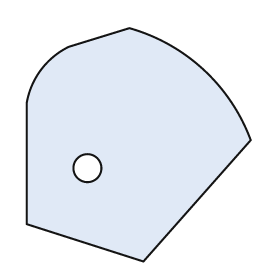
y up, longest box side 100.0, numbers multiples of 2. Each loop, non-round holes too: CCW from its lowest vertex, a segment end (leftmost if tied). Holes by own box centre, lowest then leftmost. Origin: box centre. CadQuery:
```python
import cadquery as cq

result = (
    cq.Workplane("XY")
    .moveTo(2.0, -50.0)
    .lineTo(48.0, 2.0)
    .threePointArc((28.0, 32.0), (-4.0, 50.0))
    .lineTo(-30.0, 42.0)
    .threePointArc((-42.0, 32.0), (-48.0, 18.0))
    .lineTo(-48.0, -34.0)
    .close()
    .moveTo(-22.0, -10.0)
    .circle(6.0)
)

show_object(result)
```